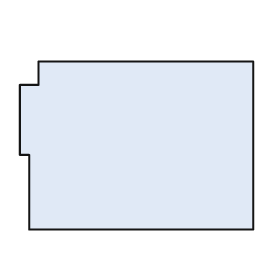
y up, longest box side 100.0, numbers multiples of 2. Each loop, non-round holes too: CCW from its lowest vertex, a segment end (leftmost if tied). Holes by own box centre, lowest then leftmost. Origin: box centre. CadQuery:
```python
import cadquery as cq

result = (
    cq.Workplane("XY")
    .moveTo(-46.0, -36.0)
    .lineTo(50.0, -36.0)
    .lineTo(50.0, 36.0)
    .lineTo(-42.0, 36.0)
    .lineTo(-42.0, 26.0)
    .lineTo(-50.0, 26.0)
    .lineTo(-50.0, -4.0)
    .lineTo(-46.0, -4.0)
    .close()
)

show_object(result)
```